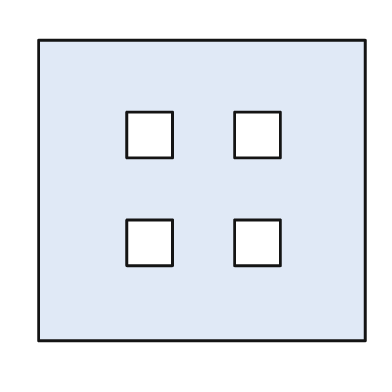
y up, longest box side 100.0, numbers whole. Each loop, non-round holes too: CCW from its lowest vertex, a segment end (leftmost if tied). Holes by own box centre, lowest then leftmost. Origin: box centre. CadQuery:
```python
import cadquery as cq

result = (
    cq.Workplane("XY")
    .moveTo(-50.0, -46.0)
    .lineTo(50.0, -46.0)
    .lineTo(50.0, 46.0)
    .lineTo(-50.0, 46.0)
    .close()
    .moveTo(-23.0, -23.0)
    .lineTo(-9.0, -23.0)
    .lineTo(-9.0, -9.0)
    .lineTo(-23.0, -9.0)
    .close()
    .moveTo(10.0, -23.0)
    .lineTo(24.0, -23.0)
    .lineTo(24.0, -9.0)
    .lineTo(10.0, -9.0)
    .close()
    .moveTo(-23.0, 10.0)
    .lineTo(-9.0, 10.0)
    .lineTo(-9.0, 24.0)
    .lineTo(-23.0, 24.0)
    .close()
    .moveTo(10.0, 10.0)
    .lineTo(24.0, 10.0)
    .lineTo(24.0, 24.0)
    .lineTo(10.0, 24.0)
    .close()
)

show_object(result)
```